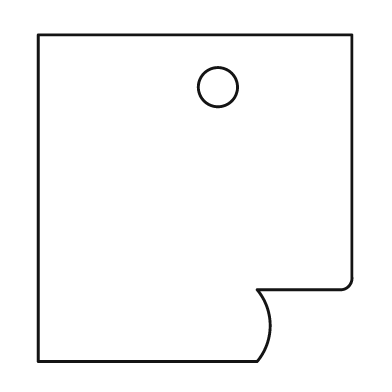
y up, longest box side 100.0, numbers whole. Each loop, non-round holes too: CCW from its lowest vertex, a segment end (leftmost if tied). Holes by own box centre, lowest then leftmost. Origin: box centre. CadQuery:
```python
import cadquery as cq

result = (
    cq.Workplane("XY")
    .moveTo(-48.0, -50.0)
    .lineTo(19.0, -50.0)
    .threePointArc((23.0, -39.0), (19.0, -28.0))
    .lineTo(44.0, -28.0)
    .threePointArc((47.0, -27.0), (48.0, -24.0))
    .lineTo(48.0, 50.0)
    .lineTo(-48.0, 50.0)
    .close()
    .moveTo(7.0, 34.0)
    .circle(6.0)
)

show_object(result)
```